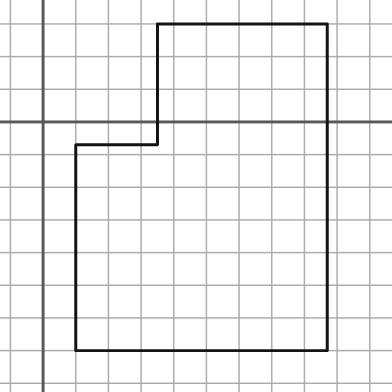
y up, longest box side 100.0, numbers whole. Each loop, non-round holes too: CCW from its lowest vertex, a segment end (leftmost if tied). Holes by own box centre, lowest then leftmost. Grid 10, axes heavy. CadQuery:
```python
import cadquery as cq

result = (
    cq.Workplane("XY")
    .moveTo(10.0, -70.0)
    .lineTo(87.0, -70.0)
    .lineTo(87.0, 30.0)
    .lineTo(35.0, 30.0)
    .lineTo(35.0, -7.0)
    .lineTo(10.0, -7.0)
    .close()
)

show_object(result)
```